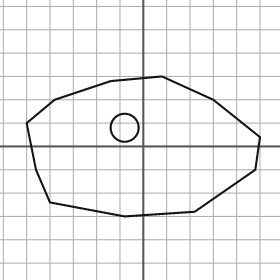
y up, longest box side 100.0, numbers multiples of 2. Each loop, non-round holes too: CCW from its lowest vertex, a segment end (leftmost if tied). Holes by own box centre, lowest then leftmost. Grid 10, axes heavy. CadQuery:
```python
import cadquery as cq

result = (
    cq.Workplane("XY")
    .moveTo(-8.0, -30.0)
    .lineTo(22.0, -28.0)
    .lineTo(48.0, -10.0)
    .lineTo(50.0, 4.0)
    .lineTo(30.0, 20.0)
    .lineTo(8.0, 30.0)
    .lineTo(-14.0, 28.0)
    .lineTo(-38.0, 20.0)
    .lineTo(-50.0, 10.0)
    .lineTo(-46.0, -10.0)
    .lineTo(-40.0, -24.0)
    .close()
    .moveTo(-8.0, 8.0)
    .circle(6.0)
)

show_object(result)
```